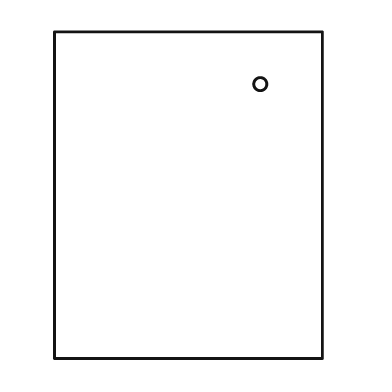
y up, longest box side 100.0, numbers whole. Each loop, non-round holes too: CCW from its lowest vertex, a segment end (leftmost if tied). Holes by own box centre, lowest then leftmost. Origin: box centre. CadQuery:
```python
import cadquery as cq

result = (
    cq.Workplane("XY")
    .moveTo(-41.0, -50.0)
    .lineTo(41.0, -50.0)
    .lineTo(41.0, 50.0)
    .lineTo(-41.0, 50.0)
    .close()
    .moveTo(22.0, 34.0)
    .circle(2.0)
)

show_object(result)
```